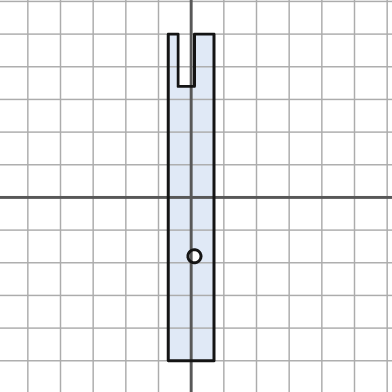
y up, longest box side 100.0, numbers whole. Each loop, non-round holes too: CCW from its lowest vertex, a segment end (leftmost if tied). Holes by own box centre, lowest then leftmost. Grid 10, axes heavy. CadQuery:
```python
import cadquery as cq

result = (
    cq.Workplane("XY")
    .moveTo(-7.0, -50.0)
    .lineTo(7.0, -50.0)
    .lineTo(7.0, 50.0)
    .lineTo(1.0, 50.0)
    .lineTo(1.0, 34.0)
    .lineTo(-4.0, 34.0)
    .lineTo(-4.0, 50.0)
    .lineTo(-7.0, 50.0)
    .close()
    .moveTo(1.0, -18.0)
    .circle(2.0)
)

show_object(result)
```